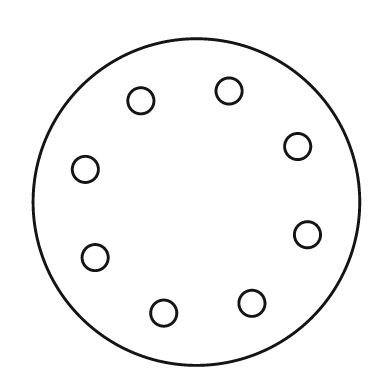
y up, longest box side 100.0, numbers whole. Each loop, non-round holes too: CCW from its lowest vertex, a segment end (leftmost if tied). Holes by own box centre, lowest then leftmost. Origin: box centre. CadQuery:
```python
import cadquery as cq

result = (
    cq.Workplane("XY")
    .moveTo(0.0, 0.0)
    .circle(50.0)
    .moveTo(-10.0, -34.0)
    .circle(4.0)
    .moveTo(17.0, -31.0)
    .circle(4.0)
    .moveTo(-31.0, -17.0)
    .circle(4.0)
    .moveTo(34.0, -10.0)
    .circle(4.0)
    .moveTo(-34.0, 10.0)
    .circle(4.0)
    .moveTo(31.0, 17.0)
    .circle(4.0)
    .moveTo(-17.0, 31.0)
    .circle(4.0)
    .moveTo(10.0, 34.0)
    .circle(4.0)
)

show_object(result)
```